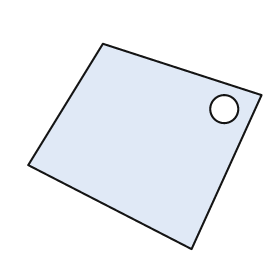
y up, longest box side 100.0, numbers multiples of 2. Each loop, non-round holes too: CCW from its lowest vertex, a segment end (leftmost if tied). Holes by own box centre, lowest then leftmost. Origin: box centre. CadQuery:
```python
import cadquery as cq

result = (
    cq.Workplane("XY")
    .moveTo(20.0, -44.0)
    .lineTo(50.0, 22.0)
    .lineTo(-18.0, 44.0)
    .lineTo(-50.0, -8.0)
    .close()
    .moveTo(34.0, 16.0)
    .circle(6.0)
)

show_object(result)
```